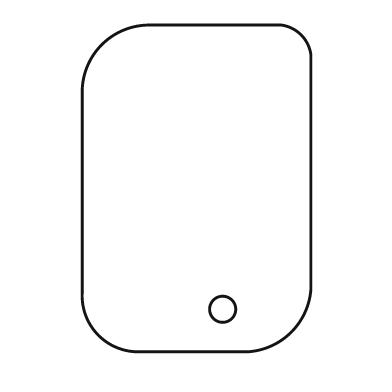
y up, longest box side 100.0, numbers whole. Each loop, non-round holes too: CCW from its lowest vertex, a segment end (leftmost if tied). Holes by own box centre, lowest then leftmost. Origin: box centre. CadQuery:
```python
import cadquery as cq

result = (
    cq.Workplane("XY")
    .moveTo(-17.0, -50.0)
    .lineTo(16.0, -50.0)
    .threePointArc((29.0, -44.0), (35.0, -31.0))
    .lineTo(35.0, 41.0)
    .threePointArc((32.0, 47.0), (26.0, 50.0))
    .lineTo(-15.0, 50.0)
    .threePointArc((-29.0, 44.0), (-35.0, 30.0))
    .lineTo(-35.0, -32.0)
    .threePointArc((-30.0, -45.0), (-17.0, -50.0))
    .close()
    .moveTo(8.0, -37.0)
    .circle(4.0)
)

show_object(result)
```